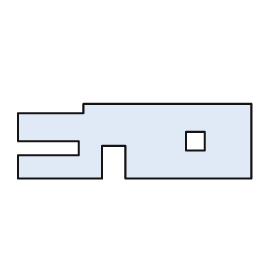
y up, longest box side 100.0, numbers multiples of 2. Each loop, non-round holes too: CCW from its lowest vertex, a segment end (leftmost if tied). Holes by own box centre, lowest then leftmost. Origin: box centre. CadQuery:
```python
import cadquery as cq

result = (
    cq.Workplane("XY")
    .moveTo(-50.0, -16.0)
    .lineTo(-14.0, -16.0)
    .lineTo(-14.0, -2.0)
    .lineTo(-4.0, -2.0)
    .lineTo(-4.0, -16.0)
    .lineTo(50.0, -16.0)
    .lineTo(50.0, 16.0)
    .lineTo(-22.0, 16.0)
    .lineTo(-22.0, 12.0)
    .lineTo(-50.0, 12.0)
    .lineTo(-50.0, 0.0)
    .lineTo(-24.0, 0.0)
    .lineTo(-24.0, -6.0)
    .lineTo(-50.0, -6.0)
    .close()
    .moveTo(22.0, -4.0)
    .lineTo(30.0, -4.0)
    .lineTo(30.0, 4.0)
    .lineTo(22.0, 4.0)
    .close()
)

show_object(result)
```